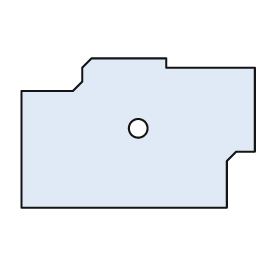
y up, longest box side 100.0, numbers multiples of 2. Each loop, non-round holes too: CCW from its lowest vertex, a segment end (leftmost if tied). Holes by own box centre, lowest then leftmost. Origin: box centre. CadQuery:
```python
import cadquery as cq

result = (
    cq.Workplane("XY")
    .moveTo(-50.0, -32.0)
    .lineTo(38.0, -32.0)
    .lineTo(38.0, -12.0)
    .lineTo(42.0, -8.0)
    .lineTo(50.0, -8.0)
    .lineTo(50.0, 28.0)
    .lineTo(12.0, 28.0)
    .lineTo(12.0, 32.0)
    .lineTo(-20.0, 32.0)
    .lineTo(-24.0, 28.0)
    .lineTo(-24.0, 22.0)
    .lineTo(-28.0, 18.0)
    .lineTo(-50.0, 18.0)
    .close()
    .moveTo(0.0, 2.0)
    .circle(4.0)
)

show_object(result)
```